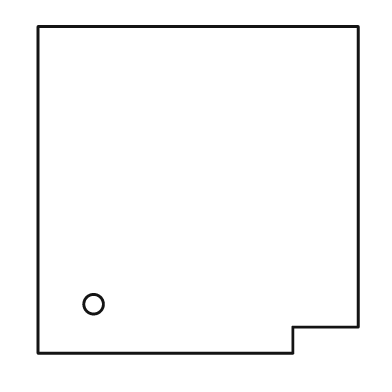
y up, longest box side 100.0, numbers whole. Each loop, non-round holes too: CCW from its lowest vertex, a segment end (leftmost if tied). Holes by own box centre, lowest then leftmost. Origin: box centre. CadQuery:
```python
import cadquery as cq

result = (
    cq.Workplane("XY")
    .moveTo(-49.0, -50.0)
    .lineTo(29.0, -50.0)
    .lineTo(29.0, -42.0)
    .lineTo(49.0, -42.0)
    .lineTo(49.0, 50.0)
    .lineTo(-49.0, 50.0)
    .close()
    .moveTo(-32.0, -35.0)
    .circle(3.0)
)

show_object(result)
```